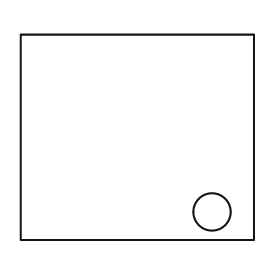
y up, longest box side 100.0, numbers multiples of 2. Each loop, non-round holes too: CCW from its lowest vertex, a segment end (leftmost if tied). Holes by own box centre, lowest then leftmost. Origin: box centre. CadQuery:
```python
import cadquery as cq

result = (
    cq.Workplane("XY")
    .moveTo(-50.0, -44.0)
    .lineTo(50.0, -44.0)
    .lineTo(50.0, 44.0)
    .lineTo(-50.0, 44.0)
    .close()
    .moveTo(32.0, -32.0)
    .circle(8.0)
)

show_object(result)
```